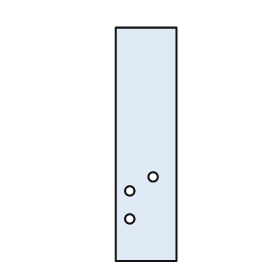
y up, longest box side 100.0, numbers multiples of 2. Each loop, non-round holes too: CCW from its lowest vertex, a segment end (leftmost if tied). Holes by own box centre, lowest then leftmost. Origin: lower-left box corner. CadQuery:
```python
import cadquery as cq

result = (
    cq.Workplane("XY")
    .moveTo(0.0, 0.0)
    .lineTo(26.0, 0.0)
    .lineTo(26.0, 100.0)
    .lineTo(0.0, 100.0)
    .close()
    .moveTo(6.0, 18.0)
    .circle(2.0)
    .moveTo(6.0, 30.0)
    .circle(2.0)
    .moveTo(16.0, 36.0)
    .circle(2.0)
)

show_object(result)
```